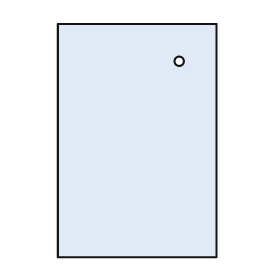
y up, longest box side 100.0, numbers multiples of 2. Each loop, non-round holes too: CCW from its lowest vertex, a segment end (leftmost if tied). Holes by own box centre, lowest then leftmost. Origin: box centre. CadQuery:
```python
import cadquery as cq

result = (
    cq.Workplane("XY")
    .moveTo(-34.0, -50.0)
    .lineTo(34.0, -50.0)
    .lineTo(34.0, 50.0)
    .lineTo(-34.0, 50.0)
    .close()
    .moveTo(18.0, 34.0)
    .circle(2.0)
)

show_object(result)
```